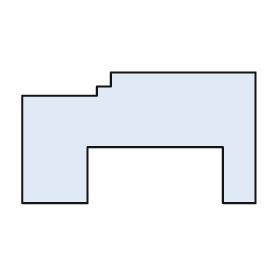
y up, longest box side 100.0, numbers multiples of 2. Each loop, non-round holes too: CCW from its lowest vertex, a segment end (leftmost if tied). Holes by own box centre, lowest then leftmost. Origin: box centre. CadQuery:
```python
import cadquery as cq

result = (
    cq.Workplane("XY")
    .moveTo(-50.0, -28.0)
    .lineTo(-22.0, -28.0)
    .lineTo(-22.0, -4.0)
    .lineTo(36.0, -4.0)
    .lineTo(36.0, -28.0)
    .lineTo(50.0, -28.0)
    .lineTo(50.0, 28.0)
    .lineTo(-12.0, 28.0)
    .lineTo(-12.0, 22.0)
    .lineTo(-18.0, 22.0)
    .lineTo(-18.0, 18.0)
    .lineTo(-50.0, 18.0)
    .close()
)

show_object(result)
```